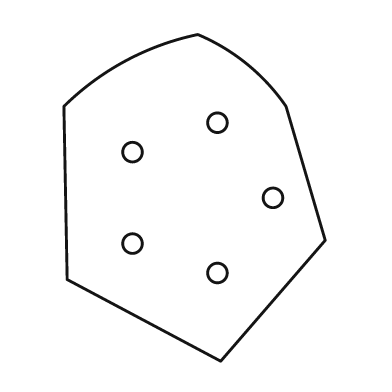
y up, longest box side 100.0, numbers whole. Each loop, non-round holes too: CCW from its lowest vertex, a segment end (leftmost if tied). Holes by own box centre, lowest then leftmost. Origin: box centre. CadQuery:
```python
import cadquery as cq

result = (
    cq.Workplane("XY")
    .moveTo(8.0, -50.0)
    .lineTo(40.0, -13.0)
    .lineTo(28.0, 28.0)
    .threePointArc((16.0, 41.0), (1.0, 50.0))
    .threePointArc((-21.0, 42.0), (-40.0, 28.0))
    .lineTo(-39.0, -25.0)
    .close()
    .moveTo(7.0, -23.0)
    .circle(3.0)
    .moveTo(-19.0, -14.0)
    .circle(3.0)
    .moveTo(24.0, 0.0)
    .circle(3.0)
    .moveTo(-19.0, 14.0)
    .circle(3.0)
    .moveTo(7.0, 23.0)
    .circle(3.0)
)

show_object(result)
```